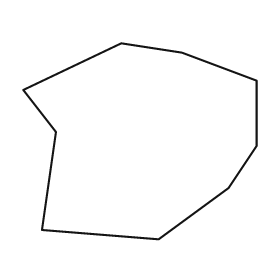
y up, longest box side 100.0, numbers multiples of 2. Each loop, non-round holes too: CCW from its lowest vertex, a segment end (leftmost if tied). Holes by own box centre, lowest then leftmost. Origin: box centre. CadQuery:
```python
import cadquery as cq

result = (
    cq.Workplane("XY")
    .moveTo(8.0, -42.0)
    .lineTo(38.0, -20.0)
    .lineTo(50.0, -2.0)
    .lineTo(50.0, 26.0)
    .lineTo(18.0, 38.0)
    .lineTo(-8.0, 42.0)
    .lineTo(-50.0, 22.0)
    .lineTo(-36.0, 4.0)
    .lineTo(-42.0, -38.0)
    .close()
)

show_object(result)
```